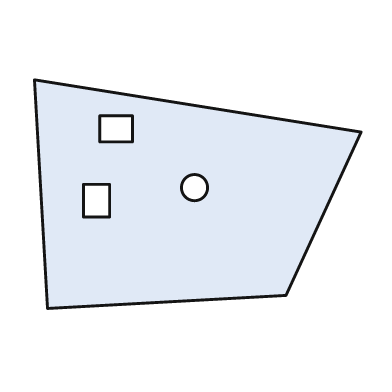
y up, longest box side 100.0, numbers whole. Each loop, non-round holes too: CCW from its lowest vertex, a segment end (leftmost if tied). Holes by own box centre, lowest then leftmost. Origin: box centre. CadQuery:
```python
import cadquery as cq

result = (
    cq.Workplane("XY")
    .moveTo(-46.0, -35.0)
    .lineTo(27.0, -31.0)
    .lineTo(50.0, 19.0)
    .lineTo(-50.0, 35.0)
    .close()
    .moveTo(-35.0, -7.0)
    .lineTo(-27.0, -7.0)
    .lineTo(-27.0, 3.0)
    .lineTo(-35.0, 3.0)
    .close()
    .moveTo(-1.0, 2.0)
    .circle(4.0)
    .moveTo(-30.0, 16.0)
    .lineTo(-20.0, 16.0)
    .lineTo(-20.0, 24.0)
    .lineTo(-30.0, 24.0)
    .close()
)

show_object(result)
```